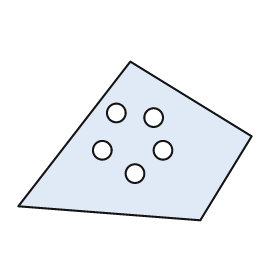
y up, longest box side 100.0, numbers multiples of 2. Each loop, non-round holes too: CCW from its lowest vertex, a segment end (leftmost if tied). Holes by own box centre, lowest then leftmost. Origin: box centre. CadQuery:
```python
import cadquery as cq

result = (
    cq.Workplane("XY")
    .moveTo(28.0, -34.0)
    .lineTo(50.0, 2.0)
    .lineTo(-2.0, 34.0)
    .lineTo(-50.0, -28.0)
    .close()
    .moveTo(0.0, -14.0)
    .circle(4.0)
    .moveTo(-14.0, -4.0)
    .circle(4.0)
    .moveTo(12.0, -4.0)
    .circle(4.0)
    .moveTo(8.0, 10.0)
    .circle(4.0)
    .moveTo(-8.0, 12.0)
    .circle(4.0)
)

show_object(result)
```